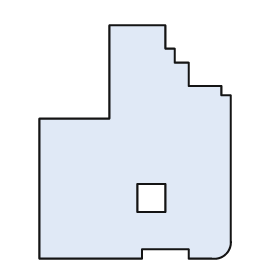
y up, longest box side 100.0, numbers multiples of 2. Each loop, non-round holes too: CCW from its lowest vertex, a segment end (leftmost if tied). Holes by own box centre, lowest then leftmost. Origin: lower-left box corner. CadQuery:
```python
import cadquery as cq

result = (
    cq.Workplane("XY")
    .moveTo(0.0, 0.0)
    .lineTo(44.0, 0.0)
    .lineTo(44.0, 4.0)
    .lineTo(64.0, 4.0)
    .lineTo(64.0, 0.0)
    .lineTo(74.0, 0.0)
    .threePointArc((80.0, 2.0), (82.0, 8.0))
    .lineTo(82.0, 70.0)
    .lineTo(78.0, 70.0)
    .lineTo(78.0, 74.0)
    .lineTo(64.0, 74.0)
    .lineTo(64.0, 84.0)
    .lineTo(58.0, 84.0)
    .lineTo(58.0, 90.0)
    .lineTo(54.0, 90.0)
    .lineTo(54.0, 100.0)
    .lineTo(30.0, 100.0)
    .lineTo(30.0, 60.0)
    .lineTo(0.0, 60.0)
    .close()
    .moveTo(42.0, 20.0)
    .lineTo(54.0, 20.0)
    .lineTo(54.0, 32.0)
    .lineTo(42.0, 32.0)
    .close()
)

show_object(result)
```